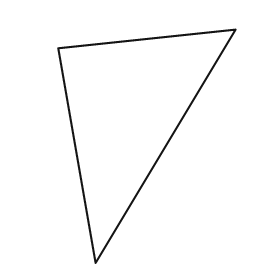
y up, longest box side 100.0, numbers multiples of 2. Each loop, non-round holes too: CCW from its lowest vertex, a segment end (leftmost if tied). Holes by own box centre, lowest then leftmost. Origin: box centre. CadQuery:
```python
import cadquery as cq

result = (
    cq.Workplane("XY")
    .moveTo(-22.0, -50.0)
    .lineTo(38.0, 50.0)
    .lineTo(-38.0, 42.0)
    .close()
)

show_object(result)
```